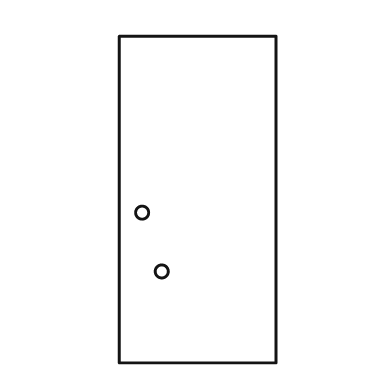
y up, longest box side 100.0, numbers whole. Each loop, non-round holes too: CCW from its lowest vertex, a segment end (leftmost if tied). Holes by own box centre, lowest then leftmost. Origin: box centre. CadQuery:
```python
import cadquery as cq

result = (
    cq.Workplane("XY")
    .moveTo(-24.0, -50.0)
    .lineTo(24.0, -50.0)
    .lineTo(24.0, 50.0)
    .lineTo(-24.0, 50.0)
    .close()
    .moveTo(-11.0, -22.0)
    .circle(2.0)
    .moveTo(-17.0, -4.0)
    .circle(2.0)
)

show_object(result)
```